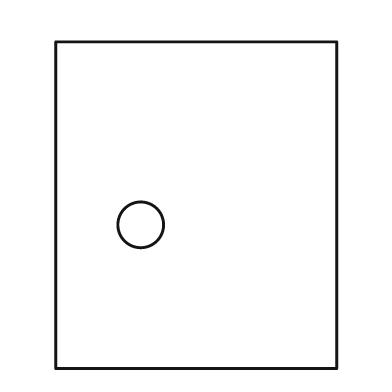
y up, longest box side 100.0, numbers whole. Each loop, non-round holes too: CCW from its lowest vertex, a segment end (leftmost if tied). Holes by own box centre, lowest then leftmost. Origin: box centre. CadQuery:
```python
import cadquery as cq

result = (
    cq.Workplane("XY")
    .moveTo(-43.0, -50.0)
    .lineTo(43.0, -50.0)
    .lineTo(43.0, 50.0)
    .lineTo(-43.0, 50.0)
    .close()
    .moveTo(-17.0, -6.0)
    .circle(7.0)
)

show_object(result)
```